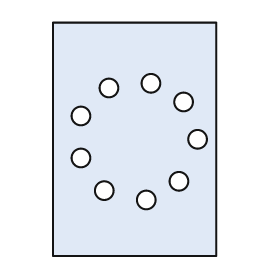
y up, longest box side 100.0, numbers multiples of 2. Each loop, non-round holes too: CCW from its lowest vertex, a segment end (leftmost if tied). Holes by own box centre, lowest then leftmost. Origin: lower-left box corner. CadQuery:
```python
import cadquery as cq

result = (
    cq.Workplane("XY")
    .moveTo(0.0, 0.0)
    .lineTo(70.0, 0.0)
    .lineTo(70.0, 100.0)
    .lineTo(0.0, 100.0)
    .close()
    .moveTo(40.0, 24.0)
    .circle(4.0)
    .moveTo(22.0, 28.0)
    .circle(4.0)
    .moveTo(54.0, 32.0)
    .circle(4.0)
    .moveTo(12.0, 42.0)
    .circle(4.0)
    .moveTo(62.0, 50.0)
    .circle(4.0)
    .moveTo(12.0, 60.0)
    .circle(4.0)
    .moveTo(56.0, 66.0)
    .circle(4.0)
    .moveTo(24.0, 72.0)
    .circle(4.0)
    .moveTo(42.0, 74.0)
    .circle(4.0)
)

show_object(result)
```